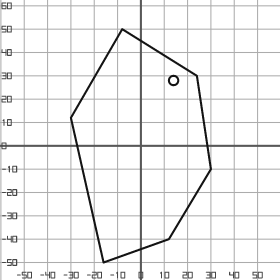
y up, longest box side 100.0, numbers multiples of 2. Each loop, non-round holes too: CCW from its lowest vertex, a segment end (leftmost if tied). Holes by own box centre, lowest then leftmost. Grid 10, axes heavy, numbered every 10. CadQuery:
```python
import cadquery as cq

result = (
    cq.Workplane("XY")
    .moveTo(-16.0, -50.0)
    .lineTo(12.0, -40.0)
    .lineTo(30.0, -10.0)
    .lineTo(24.0, 30.0)
    .lineTo(-8.0, 50.0)
    .lineTo(-30.0, 12.0)
    .close()
    .moveTo(14.0, 28.0)
    .circle(2.0)
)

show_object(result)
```